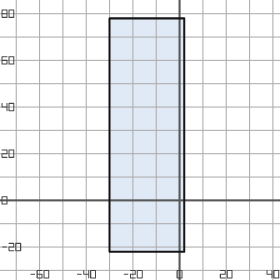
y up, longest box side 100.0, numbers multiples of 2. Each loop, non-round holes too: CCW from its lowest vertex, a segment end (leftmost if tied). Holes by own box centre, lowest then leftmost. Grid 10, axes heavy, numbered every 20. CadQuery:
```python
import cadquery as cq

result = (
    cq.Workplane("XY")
    .moveTo(-30.0, -22.0)
    .lineTo(2.0, -22.0)
    .lineTo(2.0, 78.0)
    .lineTo(-30.0, 78.0)
    .close()
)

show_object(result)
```